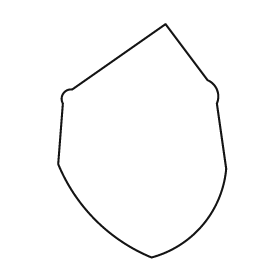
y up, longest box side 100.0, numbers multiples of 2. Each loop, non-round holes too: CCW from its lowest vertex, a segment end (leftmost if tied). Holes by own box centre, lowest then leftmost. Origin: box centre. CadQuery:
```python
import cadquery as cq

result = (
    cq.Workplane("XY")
    .moveTo(4.0, -50.0)
    .threePointArc((26.0, -36.0), (36.0, -12.0))
    .lineTo(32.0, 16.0)
    .threePointArc((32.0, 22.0), (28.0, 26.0))
    .lineTo(10.0, 50.0)
    .lineTo(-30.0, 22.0)
    .threePointArc((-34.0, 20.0), (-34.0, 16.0))
    .lineTo(-36.0, -10.0)
    .threePointArc((-20.0, -34.0), (4.0, -50.0))
    .close()
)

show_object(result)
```